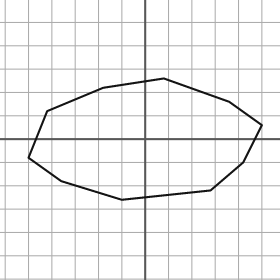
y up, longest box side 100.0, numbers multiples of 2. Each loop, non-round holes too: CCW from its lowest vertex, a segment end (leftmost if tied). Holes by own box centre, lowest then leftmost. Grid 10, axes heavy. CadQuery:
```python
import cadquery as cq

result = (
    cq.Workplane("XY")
    .moveTo(-10.0, -26.0)
    .lineTo(28.0, -22.0)
    .lineTo(42.0, -10.0)
    .lineTo(50.0, 6.0)
    .lineTo(36.0, 16.0)
    .lineTo(8.0, 26.0)
    .lineTo(-18.0, 22.0)
    .lineTo(-42.0, 12.0)
    .lineTo(-50.0, -8.0)
    .lineTo(-36.0, -18.0)
    .close()
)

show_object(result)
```